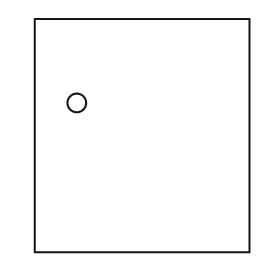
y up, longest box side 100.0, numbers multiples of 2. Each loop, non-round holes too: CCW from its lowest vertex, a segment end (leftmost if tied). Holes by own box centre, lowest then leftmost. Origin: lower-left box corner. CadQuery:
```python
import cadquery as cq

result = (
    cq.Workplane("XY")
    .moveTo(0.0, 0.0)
    .lineTo(92.0, 0.0)
    .lineTo(92.0, 100.0)
    .lineTo(0.0, 100.0)
    .close()
    .moveTo(18.0, 64.0)
    .circle(4.0)
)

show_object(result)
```